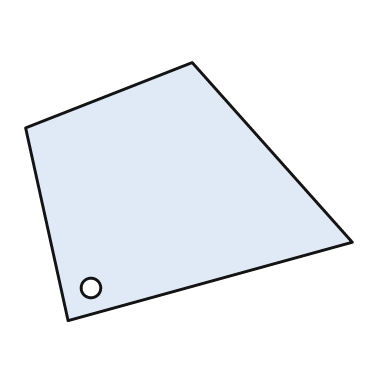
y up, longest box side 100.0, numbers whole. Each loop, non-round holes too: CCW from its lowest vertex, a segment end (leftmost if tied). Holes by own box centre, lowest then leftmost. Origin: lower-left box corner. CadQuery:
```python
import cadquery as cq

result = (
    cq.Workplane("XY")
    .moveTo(13.0, 0.0)
    .lineTo(100.0, 24.0)
    .lineTo(51.0, 79.0)
    .lineTo(0.0, 59.0)
    .close()
    .moveTo(20.0, 10.0)
    .circle(3.0)
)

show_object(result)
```